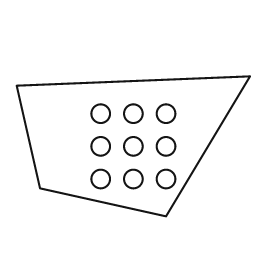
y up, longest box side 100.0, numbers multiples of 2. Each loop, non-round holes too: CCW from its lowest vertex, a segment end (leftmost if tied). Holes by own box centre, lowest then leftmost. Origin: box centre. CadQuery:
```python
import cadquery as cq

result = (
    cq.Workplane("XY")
    .moveTo(14.0, -30.0)
    .lineTo(50.0, 30.0)
    .lineTo(-50.0, 26.0)
    .lineTo(-40.0, -18.0)
    .close()
    .moveTo(-14.0, -14.0)
    .circle(4.0)
    .moveTo(0.0, -14.0)
    .circle(4.0)
    .moveTo(14.0, -14.0)
    .circle(4.0)
    .moveTo(-14.0, 0.0)
    .circle(4.0)
    .moveTo(0.0, 0.0)
    .circle(4.0)
    .moveTo(14.0, 0.0)
    .circle(4.0)
    .moveTo(-14.0, 14.0)
    .circle(4.0)
    .moveTo(0.0, 14.0)
    .circle(4.0)
    .moveTo(14.0, 14.0)
    .circle(4.0)
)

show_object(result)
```